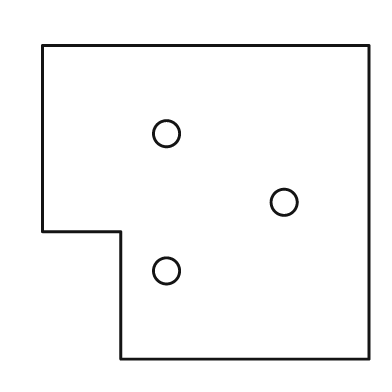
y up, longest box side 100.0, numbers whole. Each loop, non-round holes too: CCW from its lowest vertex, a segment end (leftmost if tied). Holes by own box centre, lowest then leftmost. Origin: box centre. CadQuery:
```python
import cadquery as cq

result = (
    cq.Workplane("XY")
    .moveTo(-26.0, -48.0)
    .lineTo(50.0, -48.0)
    .lineTo(50.0, 48.0)
    .lineTo(-50.0, 48.0)
    .lineTo(-50.0, -9.0)
    .lineTo(-26.0, -9.0)
    .close()
    .moveTo(-12.0, -21.0)
    .circle(4.0)
    .moveTo(24.0, 0.0)
    .circle(4.0)
    .moveTo(-12.0, 21.0)
    .circle(4.0)
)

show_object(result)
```